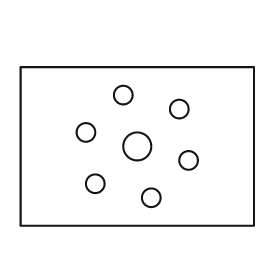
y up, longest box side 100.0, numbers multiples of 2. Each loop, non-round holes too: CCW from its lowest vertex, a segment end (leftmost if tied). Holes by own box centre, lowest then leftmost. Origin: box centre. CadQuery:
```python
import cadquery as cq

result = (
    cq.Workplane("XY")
    .moveTo(-50.0, -34.0)
    .lineTo(50.0, -34.0)
    .lineTo(50.0, 34.0)
    .lineTo(-50.0, 34.0)
    .close()
    .moveTo(6.0, -22.0)
    .circle(4.0)
    .moveTo(-18.0, -16.0)
    .circle(4.0)
    .moveTo(22.0, -6.0)
    .circle(4.0)
    .moveTo(0.0, 0.0)
    .circle(6.0)
    .moveTo(-22.0, 6.0)
    .circle(4.0)
    .moveTo(18.0, 16.0)
    .circle(4.0)
    .moveTo(-6.0, 22.0)
    .circle(4.0)
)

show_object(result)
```